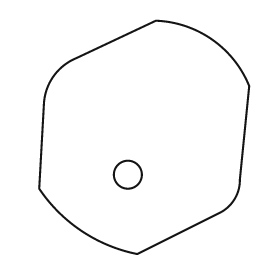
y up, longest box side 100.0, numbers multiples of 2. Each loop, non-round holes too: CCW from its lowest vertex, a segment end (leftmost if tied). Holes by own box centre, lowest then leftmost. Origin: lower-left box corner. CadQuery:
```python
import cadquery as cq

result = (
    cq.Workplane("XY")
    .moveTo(42.0, 0.0)
    .lineTo(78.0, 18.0)
    .threePointArc((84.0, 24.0), (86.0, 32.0))
    .lineTo(90.0, 72.0)
    .threePointArc((74.0, 92.0), (50.0, 100.0))
    .lineTo(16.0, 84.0)
    .threePointArc((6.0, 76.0), (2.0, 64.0))
    .lineTo(0.0, 28.0)
    .threePointArc((18.0, 10.0), (42.0, 0.0))
    .close()
    .moveTo(38.0, 34.0)
    .circle(6.0)
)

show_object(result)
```